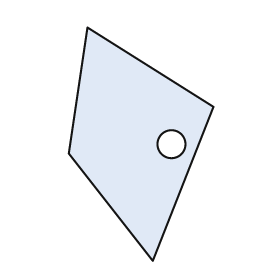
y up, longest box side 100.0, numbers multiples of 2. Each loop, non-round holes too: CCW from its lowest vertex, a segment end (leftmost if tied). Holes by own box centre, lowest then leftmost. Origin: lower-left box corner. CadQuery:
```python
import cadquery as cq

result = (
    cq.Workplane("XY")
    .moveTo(36.0, 0.0)
    .lineTo(62.0, 66.0)
    .lineTo(8.0, 100.0)
    .lineTo(0.0, 46.0)
    .close()
    .moveTo(44.0, 50.0)
    .circle(6.0)
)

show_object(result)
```